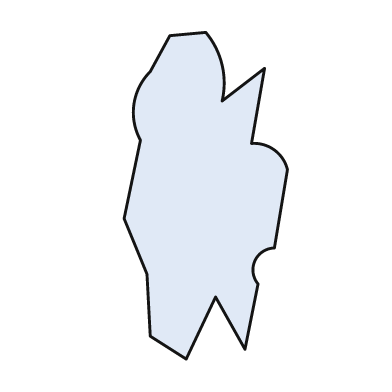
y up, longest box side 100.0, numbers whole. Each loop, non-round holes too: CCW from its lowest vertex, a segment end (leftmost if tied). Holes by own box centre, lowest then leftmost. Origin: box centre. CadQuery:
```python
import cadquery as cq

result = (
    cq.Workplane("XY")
    .moveTo(-6.0, -50.0)
    .lineTo(3.0, -31.0)
    .lineTo(12.0, -47.0)
    .lineTo(16.0, -27.0)
    .threePointArc((15.0, -20.0), (21.0, -16.0))
    .lineTo(25.0, 8.0)
    .threePointArc((21.0, 14.0), (14.0, 16.0))
    .lineTo(18.0, 39.0)
    .lineTo(5.0, 29.0)
    .threePointArc((5.0, 40.0), (0.0, 50.0))
    .lineTo(-11.0, 49.0)
    .lineTo(-17.0, 38.0)
    .threePointArc((-22.0, 28.0), (-20.0, 17.0))
    .lineTo(-25.0, -7.0)
    .lineTo(-18.0, -24.0)
    .lineTo(-17.0, -43.0)
    .close()
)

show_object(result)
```